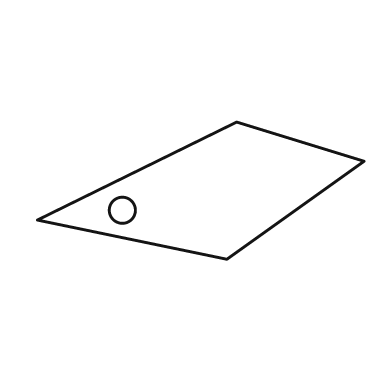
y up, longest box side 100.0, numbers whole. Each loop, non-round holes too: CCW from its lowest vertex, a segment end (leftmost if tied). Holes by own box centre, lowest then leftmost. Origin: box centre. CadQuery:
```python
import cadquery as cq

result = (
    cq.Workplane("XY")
    .moveTo(8.0, -21.0)
    .lineTo(50.0, 9.0)
    .lineTo(11.0, 21.0)
    .lineTo(-50.0, -9.0)
    .close()
    .moveTo(-24.0, -6.0)
    .circle(4.0)
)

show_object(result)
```